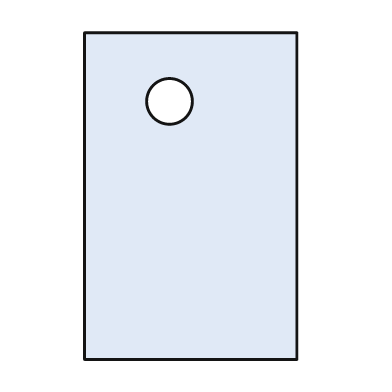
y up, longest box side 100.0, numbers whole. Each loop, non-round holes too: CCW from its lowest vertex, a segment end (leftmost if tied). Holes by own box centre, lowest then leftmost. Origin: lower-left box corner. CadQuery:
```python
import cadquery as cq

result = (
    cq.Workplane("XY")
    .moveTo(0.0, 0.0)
    .lineTo(65.0, 0.0)
    .lineTo(65.0, 100.0)
    .lineTo(0.0, 100.0)
    .close()
    .moveTo(26.0, 79.0)
    .circle(7.0)
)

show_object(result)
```